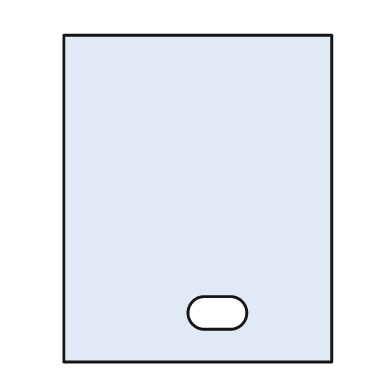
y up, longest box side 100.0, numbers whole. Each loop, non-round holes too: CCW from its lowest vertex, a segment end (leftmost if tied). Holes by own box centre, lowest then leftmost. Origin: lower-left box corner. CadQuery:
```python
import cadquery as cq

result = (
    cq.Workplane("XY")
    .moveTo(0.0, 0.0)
    .lineTo(82.0, 0.0)
    .lineTo(82.0, 100.0)
    .lineTo(0.0, 100.0)
    .close()
    .moveTo(43.0, 10.0)
    .lineTo(51.0, 10.0)
    .threePointArc((56.0, 15.0), (51.0, 20.0))
    .lineTo(43.0, 20.0)
    .threePointArc((38.0, 15.0), (43.0, 10.0))
    .close()
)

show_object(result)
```